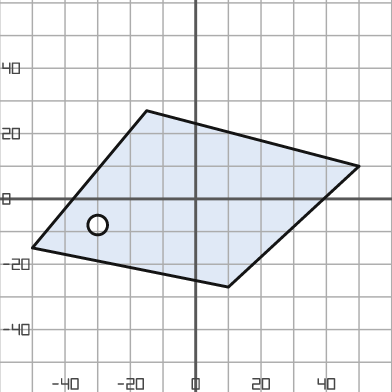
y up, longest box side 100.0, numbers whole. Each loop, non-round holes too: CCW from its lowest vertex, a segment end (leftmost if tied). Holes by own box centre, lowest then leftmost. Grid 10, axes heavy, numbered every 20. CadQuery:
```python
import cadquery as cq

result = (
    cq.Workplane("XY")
    .moveTo(10.0, -27.0)
    .lineTo(50.0, 10.0)
    .lineTo(-15.0, 27.0)
    .lineTo(-50.0, -15.0)
    .close()
    .moveTo(-30.0, -8.0)
    .circle(3.0)
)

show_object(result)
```